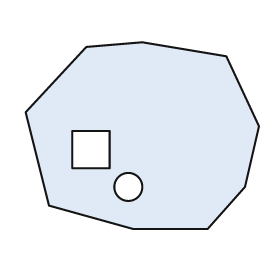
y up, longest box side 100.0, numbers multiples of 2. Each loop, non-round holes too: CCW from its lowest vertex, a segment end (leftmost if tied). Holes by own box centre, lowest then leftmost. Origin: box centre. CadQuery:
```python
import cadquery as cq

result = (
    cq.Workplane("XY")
    .moveTo(-4.0, -40.0)
    .lineTo(28.0, -40.0)
    .lineTo(44.0, -22.0)
    .lineTo(50.0, 4.0)
    .lineTo(36.0, 34.0)
    .lineTo(0.0, 40.0)
    .lineTo(-24.0, 38.0)
    .lineTo(-50.0, 10.0)
    .lineTo(-40.0, -30.0)
    .close()
    .moveTo(-6.0, -22.0)
    .circle(6.0)
    .moveTo(-30.0, -14.0)
    .lineTo(-14.0, -14.0)
    .lineTo(-14.0, 2.0)
    .lineTo(-30.0, 2.0)
    .close()
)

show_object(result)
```